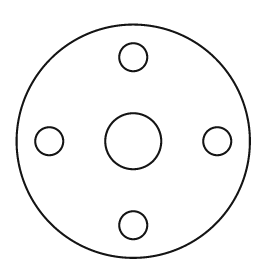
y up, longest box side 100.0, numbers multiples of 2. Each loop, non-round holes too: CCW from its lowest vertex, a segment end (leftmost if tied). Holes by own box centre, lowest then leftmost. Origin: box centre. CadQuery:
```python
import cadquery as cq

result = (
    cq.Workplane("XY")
    .moveTo(0.0, 0.0)
    .circle(50.0)
    .moveTo(0.0, -36.0)
    .circle(6.0)
    .moveTo(-36.0, 0.0)
    .circle(6.0)
    .moveTo(0.0, 0.0)
    .circle(12.0)
    .moveTo(36.0, 0.0)
    .circle(6.0)
    .moveTo(0.0, 36.0)
    .circle(6.0)
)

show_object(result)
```